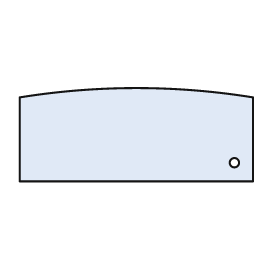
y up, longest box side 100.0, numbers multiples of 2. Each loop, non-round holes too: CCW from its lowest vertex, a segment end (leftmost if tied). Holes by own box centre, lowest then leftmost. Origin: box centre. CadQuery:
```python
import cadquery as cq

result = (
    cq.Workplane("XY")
    .moveTo(-50.0, -20.0)
    .lineTo(50.0, -20.0)
    .lineTo(50.0, 16.0)
    .threePointArc((0.0, 20.0), (-50.0, 16.0))
    .close()
    .moveTo(42.0, -12.0)
    .circle(2.0)
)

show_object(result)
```